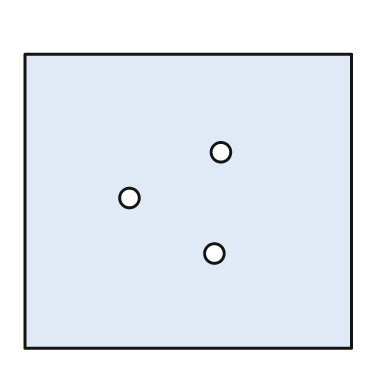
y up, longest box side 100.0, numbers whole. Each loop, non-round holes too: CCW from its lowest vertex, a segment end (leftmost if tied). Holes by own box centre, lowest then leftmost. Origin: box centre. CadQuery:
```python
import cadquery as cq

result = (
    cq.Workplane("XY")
    .moveTo(-50.0, -45.0)
    .lineTo(50.0, -45.0)
    .lineTo(50.0, 45.0)
    .lineTo(-50.0, 45.0)
    .close()
    .moveTo(8.0, -16.0)
    .circle(3.0)
    .moveTo(-18.0, 1.0)
    .circle(3.0)
    .moveTo(10.0, 15.0)
    .circle(3.0)
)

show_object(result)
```